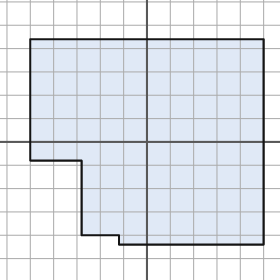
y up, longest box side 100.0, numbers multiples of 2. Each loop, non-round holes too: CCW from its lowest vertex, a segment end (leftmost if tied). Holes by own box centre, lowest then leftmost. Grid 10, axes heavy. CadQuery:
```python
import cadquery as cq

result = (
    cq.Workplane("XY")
    .moveTo(-12.0, -44.0)
    .lineTo(50.0, -44.0)
    .lineTo(50.0, 44.0)
    .lineTo(-50.0, 44.0)
    .lineTo(-50.0, -8.0)
    .lineTo(-28.0, -8.0)
    .lineTo(-28.0, -40.0)
    .lineTo(-12.0, -40.0)
    .close()
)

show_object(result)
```